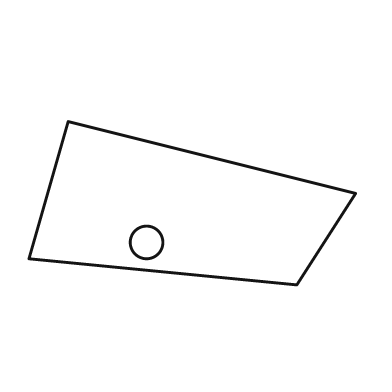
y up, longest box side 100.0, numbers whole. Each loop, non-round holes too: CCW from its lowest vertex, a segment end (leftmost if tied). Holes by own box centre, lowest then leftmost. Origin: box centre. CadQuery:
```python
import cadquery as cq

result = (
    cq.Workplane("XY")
    .moveTo(32.0, -25.0)
    .lineTo(50.0, 3.0)
    .lineTo(-38.0, 25.0)
    .lineTo(-50.0, -17.0)
    .close()
    .moveTo(-14.0, -12.0)
    .circle(5.0)
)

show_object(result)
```